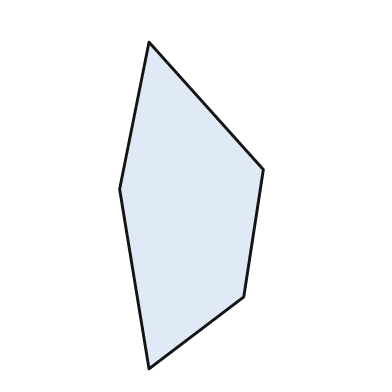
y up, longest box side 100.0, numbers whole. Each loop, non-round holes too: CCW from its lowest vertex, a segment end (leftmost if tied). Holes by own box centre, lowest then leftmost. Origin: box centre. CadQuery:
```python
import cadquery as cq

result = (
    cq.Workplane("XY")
    .moveTo(-13.0, -50.0)
    .lineTo(16.0, -28.0)
    .lineTo(22.0, 11.0)
    .lineTo(-13.0, 50.0)
    .lineTo(-22.0, 5.0)
    .close()
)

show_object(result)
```